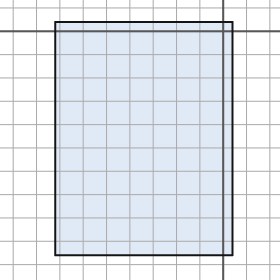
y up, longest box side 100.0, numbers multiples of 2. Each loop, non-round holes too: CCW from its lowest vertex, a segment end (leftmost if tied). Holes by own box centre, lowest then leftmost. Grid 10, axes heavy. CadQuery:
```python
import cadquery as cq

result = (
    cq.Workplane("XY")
    .moveTo(-72.0, -96.0)
    .lineTo(4.0, -96.0)
    .lineTo(4.0, 4.0)
    .lineTo(-72.0, 4.0)
    .close()
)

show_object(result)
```